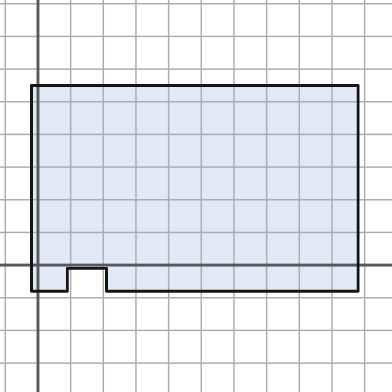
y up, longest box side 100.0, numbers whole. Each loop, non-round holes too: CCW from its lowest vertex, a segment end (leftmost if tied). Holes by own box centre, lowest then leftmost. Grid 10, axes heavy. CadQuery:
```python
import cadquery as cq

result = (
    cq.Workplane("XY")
    .moveTo(-2.0, -8.0)
    .lineTo(9.0, -8.0)
    .lineTo(9.0, -1.0)
    .lineTo(21.0, -1.0)
    .lineTo(21.0, -8.0)
    .lineTo(98.0, -8.0)
    .lineTo(98.0, 55.0)
    .lineTo(-2.0, 55.0)
    .close()
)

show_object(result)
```